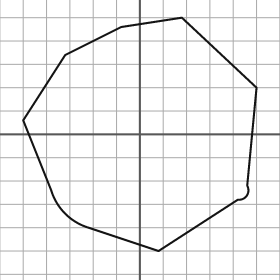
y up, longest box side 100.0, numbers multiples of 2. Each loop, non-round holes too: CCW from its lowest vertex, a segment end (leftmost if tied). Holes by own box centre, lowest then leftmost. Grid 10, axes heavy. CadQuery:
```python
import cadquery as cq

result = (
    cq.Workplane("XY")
    .moveTo(8.0, -50.0)
    .lineTo(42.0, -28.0)
    .threePointArc((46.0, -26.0), (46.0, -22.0))
    .lineTo(50.0, 20.0)
    .lineTo(18.0, 50.0)
    .lineTo(-8.0, 46.0)
    .lineTo(-32.0, 34.0)
    .lineTo(-50.0, 6.0)
    .lineTo(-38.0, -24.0)
    .threePointArc((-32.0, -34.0), (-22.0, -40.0))
    .close()
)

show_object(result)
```